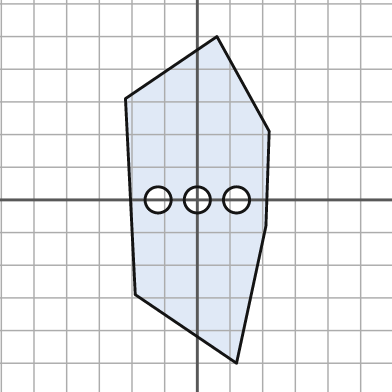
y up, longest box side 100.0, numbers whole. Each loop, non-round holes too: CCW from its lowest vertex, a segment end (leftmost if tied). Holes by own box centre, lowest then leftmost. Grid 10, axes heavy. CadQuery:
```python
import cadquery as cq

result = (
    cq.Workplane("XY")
    .moveTo(12.0, -50.0)
    .lineTo(21.0, -8.0)
    .lineTo(22.0, 21.0)
    .lineTo(6.0, 50.0)
    .lineTo(-22.0, 31.0)
    .lineTo(-19.0, -29.0)
    .close()
    .moveTo(-12.0, 0.0)
    .circle(4.0)
    .moveTo(0.0, 0.0)
    .circle(4.0)
    .moveTo(12.0, 0.0)
    .circle(4.0)
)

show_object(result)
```